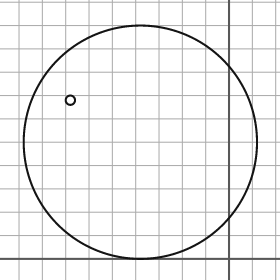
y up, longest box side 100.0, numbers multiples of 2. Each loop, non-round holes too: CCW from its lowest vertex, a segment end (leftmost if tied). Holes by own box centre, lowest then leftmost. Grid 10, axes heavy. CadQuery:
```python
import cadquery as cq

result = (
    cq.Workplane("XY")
    .moveTo(-38.0, 50.0)
    .circle(50.0)
    .moveTo(-68.0, 68.0)
    .circle(2.0)
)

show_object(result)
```